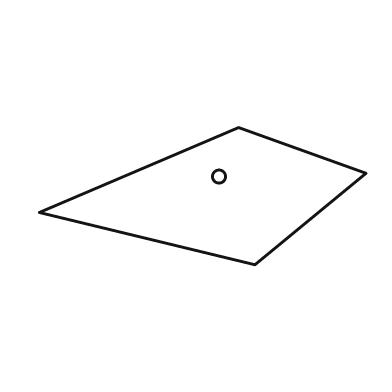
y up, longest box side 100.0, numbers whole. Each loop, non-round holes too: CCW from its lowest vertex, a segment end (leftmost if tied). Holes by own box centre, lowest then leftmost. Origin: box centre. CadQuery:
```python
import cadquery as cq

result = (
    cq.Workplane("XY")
    .moveTo(16.0, -21.0)
    .lineTo(50.0, 7.0)
    .lineTo(11.0, 21.0)
    .lineTo(-50.0, -5.0)
    .close()
    .moveTo(5.0, 6.0)
    .circle(2.0)
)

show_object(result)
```